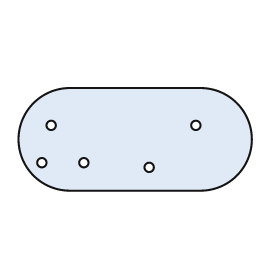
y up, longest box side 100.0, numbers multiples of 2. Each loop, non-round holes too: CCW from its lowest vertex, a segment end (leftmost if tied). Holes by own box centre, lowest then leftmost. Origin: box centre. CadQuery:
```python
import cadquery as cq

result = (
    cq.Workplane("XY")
    .moveTo(-28.0, -22.0)
    .lineTo(28.0, -22.0)
    .threePointArc((50.0, 0.0), (28.0, 22.0))
    .lineTo(-28.0, 22.0)
    .threePointArc((-50.0, 0.0), (-28.0, -22.0))
    .close()
    .moveTo(6.0, -12.0)
    .circle(2.0)
    .moveTo(-40.0, -10.0)
    .circle(2.0)
    .moveTo(-22.0, -10.0)
    .circle(2.0)
    .moveTo(-36.0, 6.0)
    .circle(2.0)
    .moveTo(26.0, 6.0)
    .circle(2.0)
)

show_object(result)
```